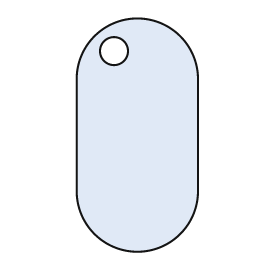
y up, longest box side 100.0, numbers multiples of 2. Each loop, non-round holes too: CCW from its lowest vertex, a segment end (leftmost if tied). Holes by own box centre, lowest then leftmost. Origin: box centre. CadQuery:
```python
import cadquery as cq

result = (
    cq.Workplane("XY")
    .moveTo(-26.0, -24.0)
    .threePointArc((0.0, -50.0), (26.0, -24.0))
    .lineTo(26.0, 24.0)
    .threePointArc((0.0, 50.0), (-26.0, 24.0))
    .close()
    .moveTo(-10.0, 36.0)
    .circle(6.0)
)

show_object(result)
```